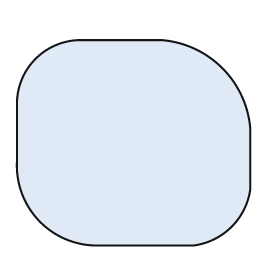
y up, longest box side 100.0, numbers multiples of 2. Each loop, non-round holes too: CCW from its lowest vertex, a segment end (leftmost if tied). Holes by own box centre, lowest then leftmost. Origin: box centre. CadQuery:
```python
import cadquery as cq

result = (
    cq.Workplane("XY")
    .moveTo(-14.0, -44.0)
    .lineTo(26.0, -44.0)
    .threePointArc((42.0, -36.0), (50.0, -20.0))
    .lineTo(50.0, 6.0)
    .threePointArc((38.0, 32.0), (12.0, 44.0))
    .lineTo(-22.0, 44.0)
    .threePointArc((-42.0, 36.0), (-50.0, 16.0))
    .lineTo(-50.0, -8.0)
    .threePointArc((-40.0, -34.0), (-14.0, -44.0))
    .close()
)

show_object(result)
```